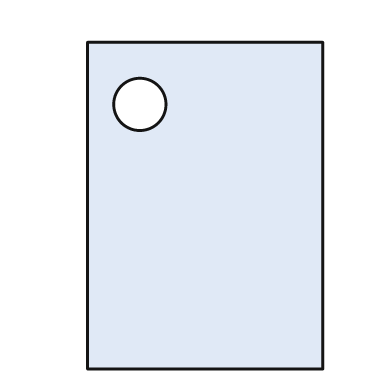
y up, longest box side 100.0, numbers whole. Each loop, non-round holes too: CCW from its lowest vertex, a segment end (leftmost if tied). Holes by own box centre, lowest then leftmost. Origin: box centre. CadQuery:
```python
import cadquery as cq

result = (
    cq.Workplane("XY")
    .moveTo(-36.0, -50.0)
    .lineTo(36.0, -50.0)
    .lineTo(36.0, 50.0)
    .lineTo(-36.0, 50.0)
    .close()
    .moveTo(-20.0, 31.0)
    .circle(8.0)
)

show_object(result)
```